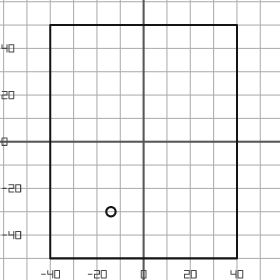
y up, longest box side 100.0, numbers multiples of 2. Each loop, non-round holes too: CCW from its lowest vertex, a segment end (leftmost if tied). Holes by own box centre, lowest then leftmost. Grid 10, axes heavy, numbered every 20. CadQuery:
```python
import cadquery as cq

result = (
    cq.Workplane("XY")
    .moveTo(-40.0, -50.0)
    .lineTo(40.0, -50.0)
    .lineTo(40.0, 50.0)
    .lineTo(-40.0, 50.0)
    .close()
    .moveTo(-14.0, -30.0)
    .circle(2.0)
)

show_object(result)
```